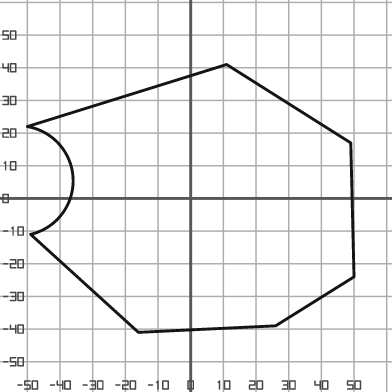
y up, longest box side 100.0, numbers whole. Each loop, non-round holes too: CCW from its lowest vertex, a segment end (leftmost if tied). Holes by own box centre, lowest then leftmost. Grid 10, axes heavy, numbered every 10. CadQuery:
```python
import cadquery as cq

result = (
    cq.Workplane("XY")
    .moveTo(-16.0, -41.0)
    .lineTo(26.0, -39.0)
    .lineTo(50.0, -24.0)
    .lineTo(49.0, 17.0)
    .lineTo(11.0, 41.0)
    .lineTo(-50.0, 22.0)
    .threePointArc((-36.0, 6.0), (-49.0, -11.0))
    .close()
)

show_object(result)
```